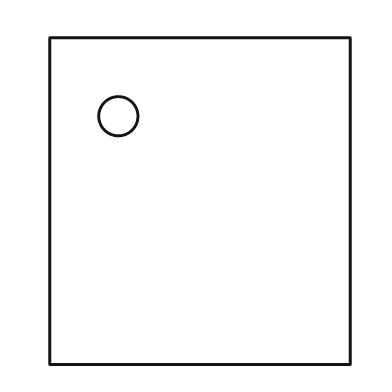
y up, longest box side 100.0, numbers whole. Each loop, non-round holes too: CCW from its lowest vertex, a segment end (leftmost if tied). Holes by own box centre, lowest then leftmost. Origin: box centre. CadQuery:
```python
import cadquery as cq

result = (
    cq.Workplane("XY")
    .moveTo(-46.0, -50.0)
    .lineTo(46.0, -50.0)
    .lineTo(46.0, 50.0)
    .lineTo(-46.0, 50.0)
    .close()
    .moveTo(-25.0, 26.0)
    .circle(6.0)
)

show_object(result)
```